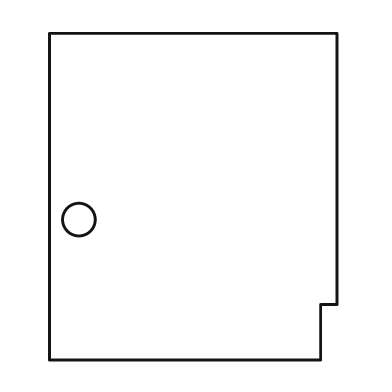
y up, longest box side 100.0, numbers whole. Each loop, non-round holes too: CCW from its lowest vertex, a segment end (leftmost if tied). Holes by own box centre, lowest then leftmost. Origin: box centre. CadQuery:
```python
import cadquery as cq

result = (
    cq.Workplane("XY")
    .moveTo(-44.0, -50.0)
    .lineTo(39.0, -50.0)
    .lineTo(39.0, -33.0)
    .lineTo(44.0, -33.0)
    .lineTo(44.0, 50.0)
    .lineTo(-44.0, 50.0)
    .close()
    .moveTo(-35.0, -7.0)
    .circle(5.0)
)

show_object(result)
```